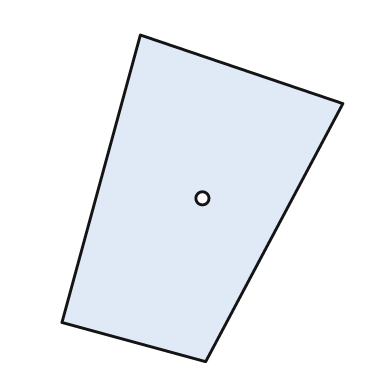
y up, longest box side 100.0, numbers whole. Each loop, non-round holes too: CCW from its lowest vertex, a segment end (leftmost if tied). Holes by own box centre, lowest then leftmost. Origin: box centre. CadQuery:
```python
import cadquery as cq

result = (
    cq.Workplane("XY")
    .moveTo(1.0, -50.0)
    .lineTo(43.0, 29.0)
    .lineTo(-19.0, 50.0)
    .lineTo(-43.0, -38.0)
    .close()
    .moveTo(0.0, 0.0)
    .circle(2.0)
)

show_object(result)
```